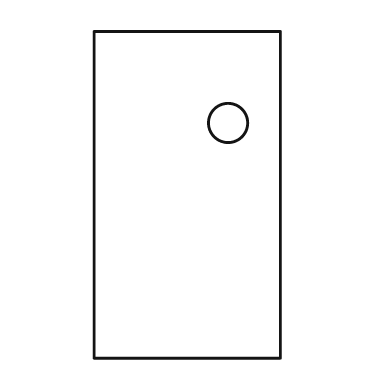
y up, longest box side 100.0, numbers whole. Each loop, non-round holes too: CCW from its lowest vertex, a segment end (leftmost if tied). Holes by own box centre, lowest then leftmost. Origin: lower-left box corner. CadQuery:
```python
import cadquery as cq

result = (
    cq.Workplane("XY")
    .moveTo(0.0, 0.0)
    .lineTo(57.0, 0.0)
    .lineTo(57.0, 100.0)
    .lineTo(0.0, 100.0)
    .close()
    .moveTo(41.0, 72.0)
    .circle(6.0)
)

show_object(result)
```